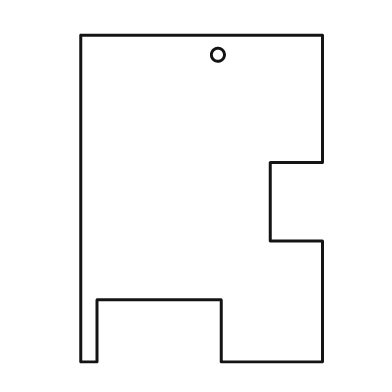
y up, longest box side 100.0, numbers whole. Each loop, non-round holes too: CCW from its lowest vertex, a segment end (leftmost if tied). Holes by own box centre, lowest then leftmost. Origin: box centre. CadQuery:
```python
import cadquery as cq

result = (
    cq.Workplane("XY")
    .moveTo(-37.0, -50.0)
    .lineTo(-32.0, -50.0)
    .lineTo(-32.0, -31.0)
    .lineTo(6.0, -31.0)
    .lineTo(6.0, -50.0)
    .lineTo(37.0, -50.0)
    .lineTo(37.0, -13.0)
    .lineTo(21.0, -13.0)
    .lineTo(21.0, 11.0)
    .lineTo(37.0, 11.0)
    .lineTo(37.0, 50.0)
    .lineTo(-37.0, 50.0)
    .close()
    .moveTo(5.0, 44.0)
    .circle(2.0)
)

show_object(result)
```